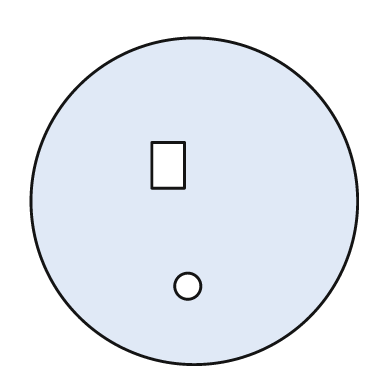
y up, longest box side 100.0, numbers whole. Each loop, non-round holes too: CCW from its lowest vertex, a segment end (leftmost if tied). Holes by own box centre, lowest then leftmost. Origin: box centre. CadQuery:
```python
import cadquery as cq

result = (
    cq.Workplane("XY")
    .moveTo(0.0, 0.0)
    .circle(50.0)
    .moveTo(-2.0, -26.0)
    .circle(4.0)
    .moveTo(-13.0, 4.0)
    .lineTo(-3.0, 4.0)
    .lineTo(-3.0, 18.0)
    .lineTo(-13.0, 18.0)
    .close()
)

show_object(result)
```